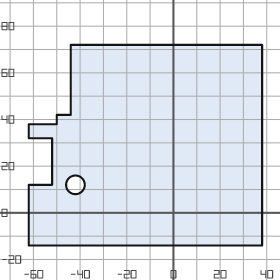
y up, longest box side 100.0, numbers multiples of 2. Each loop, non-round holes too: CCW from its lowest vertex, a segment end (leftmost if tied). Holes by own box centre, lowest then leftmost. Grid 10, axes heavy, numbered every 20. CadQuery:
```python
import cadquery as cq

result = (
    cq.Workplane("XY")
    .moveTo(-62.0, -14.0)
    .lineTo(38.0, -14.0)
    .lineTo(38.0, 72.0)
    .lineTo(-44.0, 72.0)
    .lineTo(-44.0, 42.0)
    .lineTo(-50.0, 42.0)
    .lineTo(-50.0, 38.0)
    .lineTo(-62.0, 38.0)
    .lineTo(-62.0, 32.0)
    .lineTo(-52.0, 32.0)
    .lineTo(-52.0, 12.0)
    .lineTo(-62.0, 12.0)
    .close()
    .moveTo(-42.0, 12.0)
    .circle(4.0)
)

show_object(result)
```